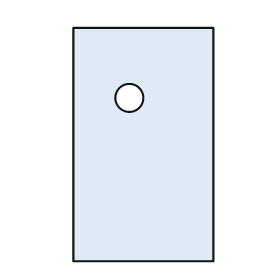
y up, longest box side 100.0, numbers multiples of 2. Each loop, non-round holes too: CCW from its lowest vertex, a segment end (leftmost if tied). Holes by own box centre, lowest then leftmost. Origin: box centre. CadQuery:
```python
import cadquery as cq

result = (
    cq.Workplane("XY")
    .moveTo(-30.0, -50.0)
    .lineTo(30.0, -50.0)
    .lineTo(30.0, 50.0)
    .lineTo(-30.0, 50.0)
    .close()
    .moveTo(-6.0, 20.0)
    .circle(6.0)
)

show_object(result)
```